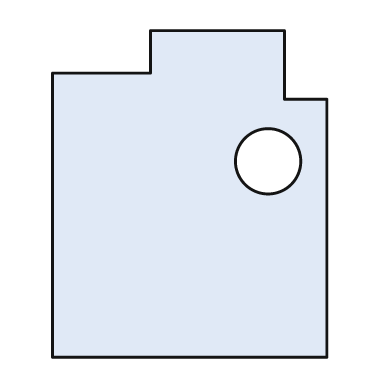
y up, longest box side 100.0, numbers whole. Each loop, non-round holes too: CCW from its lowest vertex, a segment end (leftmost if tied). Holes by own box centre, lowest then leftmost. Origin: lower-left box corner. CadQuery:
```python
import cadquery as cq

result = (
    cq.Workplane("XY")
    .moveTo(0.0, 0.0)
    .lineTo(84.0, 0.0)
    .lineTo(84.0, 79.0)
    .lineTo(71.0, 79.0)
    .lineTo(71.0, 100.0)
    .lineTo(30.0, 100.0)
    .lineTo(30.0, 87.0)
    .lineTo(0.0, 87.0)
    .close()
    .moveTo(66.0, 60.0)
    .circle(10.0)
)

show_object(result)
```